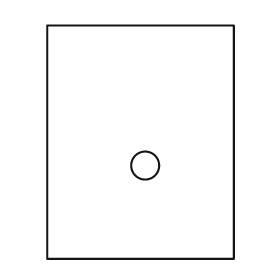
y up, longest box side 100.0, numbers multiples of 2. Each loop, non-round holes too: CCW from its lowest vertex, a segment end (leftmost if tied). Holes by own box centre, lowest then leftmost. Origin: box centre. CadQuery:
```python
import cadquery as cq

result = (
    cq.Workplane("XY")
    .moveTo(-40.0, -50.0)
    .lineTo(40.0, -50.0)
    .lineTo(40.0, 50.0)
    .lineTo(-40.0, 50.0)
    .close()
    .moveTo(2.0, -10.0)
    .circle(6.0)
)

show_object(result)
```